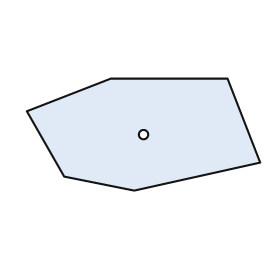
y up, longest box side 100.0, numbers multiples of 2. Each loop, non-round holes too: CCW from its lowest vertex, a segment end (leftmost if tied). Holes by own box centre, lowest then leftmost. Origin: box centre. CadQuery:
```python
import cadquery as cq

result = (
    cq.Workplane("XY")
    .moveTo(-4.0, -24.0)
    .lineTo(50.0, -12.0)
    .lineTo(36.0, 24.0)
    .lineTo(-14.0, 24.0)
    .lineTo(-50.0, 10.0)
    .lineTo(-34.0, -18.0)
    .close()
    .moveTo(0.0, 0.0)
    .circle(2.0)
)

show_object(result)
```